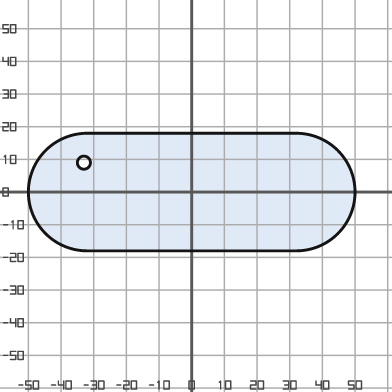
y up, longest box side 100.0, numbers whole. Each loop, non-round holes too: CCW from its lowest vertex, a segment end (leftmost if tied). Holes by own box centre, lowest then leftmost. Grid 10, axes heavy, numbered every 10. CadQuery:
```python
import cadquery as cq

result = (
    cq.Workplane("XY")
    .moveTo(-32.0, -18.0)
    .lineTo(32.0, -18.0)
    .threePointArc((50.0, 0.0), (32.0, 18.0))
    .lineTo(-32.0, 18.0)
    .threePointArc((-50.0, 0.0), (-32.0, -18.0))
    .close()
    .moveTo(-33.0, 9.0)
    .circle(2.0)
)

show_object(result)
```